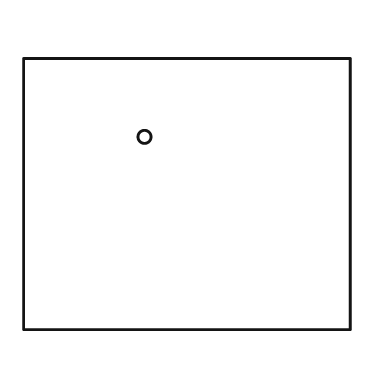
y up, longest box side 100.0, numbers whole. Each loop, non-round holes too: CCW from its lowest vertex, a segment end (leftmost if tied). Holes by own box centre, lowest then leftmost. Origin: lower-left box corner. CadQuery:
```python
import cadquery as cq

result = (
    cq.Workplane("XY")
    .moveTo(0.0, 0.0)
    .lineTo(100.0, 0.0)
    .lineTo(100.0, 83.0)
    .lineTo(0.0, 83.0)
    .close()
    .moveTo(37.0, 59.0)
    .circle(2.0)
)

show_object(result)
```